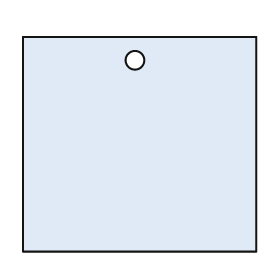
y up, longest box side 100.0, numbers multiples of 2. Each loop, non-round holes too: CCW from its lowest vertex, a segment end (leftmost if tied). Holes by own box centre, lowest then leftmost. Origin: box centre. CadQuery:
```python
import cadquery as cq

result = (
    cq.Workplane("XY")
    .moveTo(-50.0, -46.0)
    .lineTo(50.0, -46.0)
    .lineTo(50.0, 46.0)
    .lineTo(-50.0, 46.0)
    .close()
    .moveTo(-2.0, 36.0)
    .circle(4.0)
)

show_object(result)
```